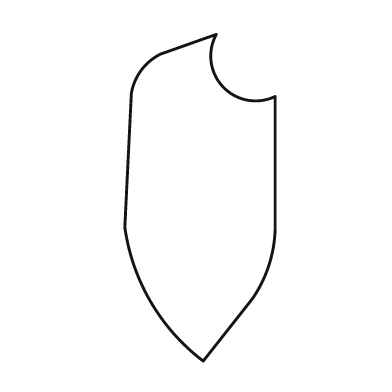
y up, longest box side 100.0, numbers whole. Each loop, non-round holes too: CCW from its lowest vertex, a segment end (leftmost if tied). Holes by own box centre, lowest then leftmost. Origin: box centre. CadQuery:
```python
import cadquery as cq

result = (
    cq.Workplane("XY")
    .moveTo(1.0, -50.0)
    .lineTo(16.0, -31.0)
    .threePointArc((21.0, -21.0), (23.0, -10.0))
    .lineTo(23.0, 31.0)
    .threePointArc((7.0, 34.0), (5.0, 50.0))
    .lineTo(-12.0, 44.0)
    .threePointArc((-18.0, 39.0), (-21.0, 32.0))
    .lineTo(-23.0, -9.0)
    .threePointArc((-15.0, -32.0), (1.0, -50.0))
    .close()
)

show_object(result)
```